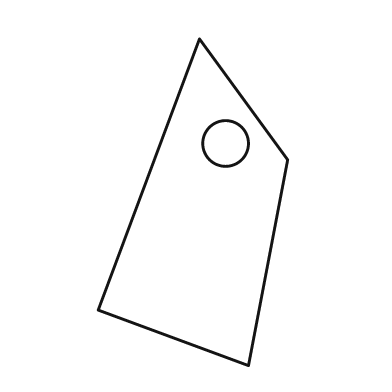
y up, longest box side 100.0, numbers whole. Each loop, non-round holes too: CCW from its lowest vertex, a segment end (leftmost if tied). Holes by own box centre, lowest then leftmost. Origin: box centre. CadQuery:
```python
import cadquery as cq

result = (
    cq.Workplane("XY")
    .moveTo(17.0, -50.0)
    .lineTo(29.0, 13.0)
    .lineTo(2.0, 50.0)
    .lineTo(-29.0, -33.0)
    .close()
    .moveTo(10.0, 18.0)
    .circle(7.0)
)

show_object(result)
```